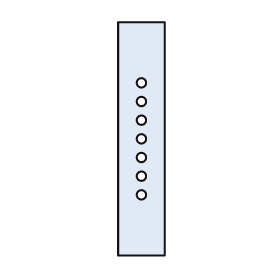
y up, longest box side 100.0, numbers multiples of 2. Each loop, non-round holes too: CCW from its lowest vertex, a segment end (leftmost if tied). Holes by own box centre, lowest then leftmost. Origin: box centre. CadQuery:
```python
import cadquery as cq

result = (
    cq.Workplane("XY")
    .moveTo(-10.0, -50.0)
    .lineTo(10.0, -50.0)
    .lineTo(10.0, 50.0)
    .lineTo(-10.0, 50.0)
    .close()
    .moveTo(0.0, -24.0)
    .circle(2.0)
    .moveTo(0.0, -16.0)
    .circle(2.0)
    .moveTo(0.0, -8.0)
    .circle(2.0)
    .moveTo(0.0, 0.0)
    .circle(2.0)
    .moveTo(0.0, 8.0)
    .circle(2.0)
    .moveTo(0.0, 16.0)
    .circle(2.0)
    .moveTo(0.0, 24.0)
    .circle(2.0)
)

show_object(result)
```